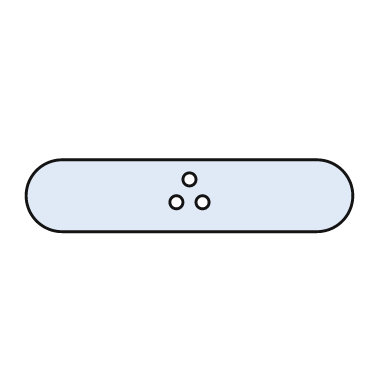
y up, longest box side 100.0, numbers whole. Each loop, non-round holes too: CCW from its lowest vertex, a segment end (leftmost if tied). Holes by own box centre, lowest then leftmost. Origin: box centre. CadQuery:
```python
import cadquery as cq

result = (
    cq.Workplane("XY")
    .moveTo(-39.0, -11.0)
    .lineTo(39.0, -11.0)
    .threePointArc((50.0, 0.0), (39.0, 11.0))
    .lineTo(-39.0, 11.0)
    .threePointArc((-50.0, 0.0), (-39.0, -11.0))
    .close()
    .moveTo(-4.0, -2.0)
    .circle(2.0)
    .moveTo(4.0, -2.0)
    .circle(2.0)
    .moveTo(0.0, 5.0)
    .circle(2.0)
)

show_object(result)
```